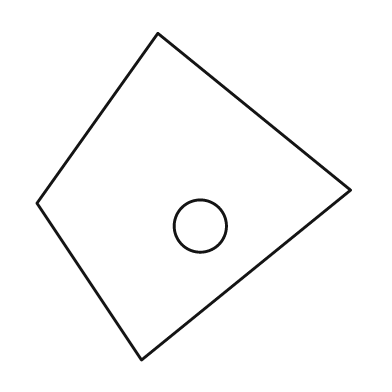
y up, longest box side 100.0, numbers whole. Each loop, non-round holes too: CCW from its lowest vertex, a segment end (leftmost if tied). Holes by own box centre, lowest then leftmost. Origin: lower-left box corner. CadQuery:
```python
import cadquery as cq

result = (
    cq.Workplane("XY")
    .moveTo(32.0, 0.0)
    .lineTo(96.0, 52.0)
    .lineTo(37.0, 100.0)
    .lineTo(0.0, 48.0)
    .close()
    .moveTo(50.0, 41.0)
    .circle(8.0)
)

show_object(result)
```